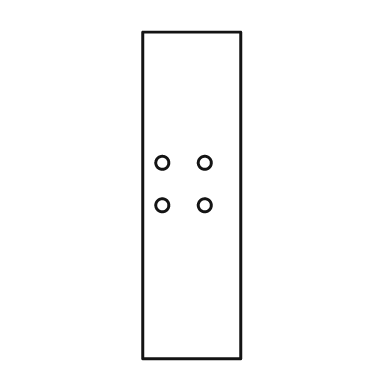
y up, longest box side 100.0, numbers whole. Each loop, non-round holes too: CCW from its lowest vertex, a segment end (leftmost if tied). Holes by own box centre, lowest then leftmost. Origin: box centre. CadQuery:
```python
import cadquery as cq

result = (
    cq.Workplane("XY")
    .moveTo(-15.0, -50.0)
    .lineTo(15.0, -50.0)
    .lineTo(15.0, 50.0)
    .lineTo(-15.0, 50.0)
    .close()
    .moveTo(-9.0, -3.0)
    .circle(2.0)
    .moveTo(4.0, -3.0)
    .circle(2.0)
    .moveTo(-9.0, 10.0)
    .circle(2.0)
    .moveTo(4.0, 10.0)
    .circle(2.0)
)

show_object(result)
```